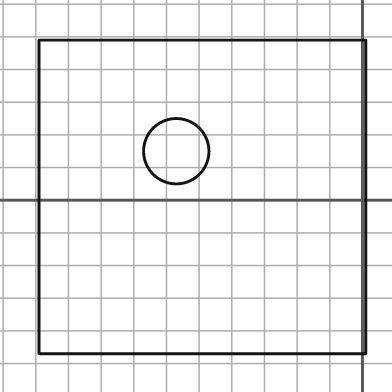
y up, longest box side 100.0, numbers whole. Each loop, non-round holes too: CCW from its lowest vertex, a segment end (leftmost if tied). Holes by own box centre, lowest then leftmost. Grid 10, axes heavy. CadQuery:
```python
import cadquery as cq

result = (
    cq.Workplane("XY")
    .moveTo(-99.0, -47.0)
    .lineTo(1.0, -47.0)
    .lineTo(1.0, 49.0)
    .lineTo(-99.0, 49.0)
    .close()
    .moveTo(-57.0, 15.0)
    .circle(10.0)
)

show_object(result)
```